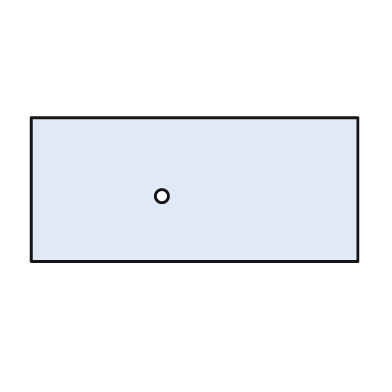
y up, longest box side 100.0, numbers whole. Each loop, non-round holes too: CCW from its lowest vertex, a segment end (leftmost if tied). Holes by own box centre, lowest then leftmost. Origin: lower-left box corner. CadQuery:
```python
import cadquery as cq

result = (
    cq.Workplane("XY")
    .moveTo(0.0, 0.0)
    .lineTo(100.0, 0.0)
    .lineTo(100.0, 44.0)
    .lineTo(0.0, 44.0)
    .close()
    .moveTo(40.0, 20.0)
    .circle(2.0)
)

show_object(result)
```